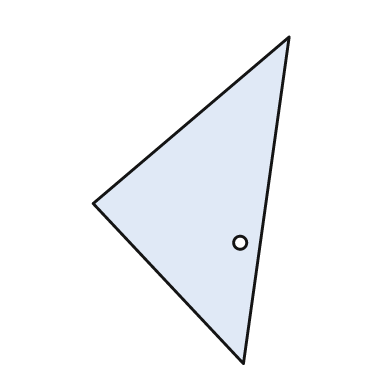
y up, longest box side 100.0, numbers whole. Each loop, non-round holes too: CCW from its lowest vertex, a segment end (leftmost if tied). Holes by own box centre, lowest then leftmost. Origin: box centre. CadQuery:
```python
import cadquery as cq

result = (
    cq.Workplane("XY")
    .moveTo(16.0, -50.0)
    .lineTo(30.0, 50.0)
    .lineTo(-30.0, -1.0)
    .close()
    .moveTo(15.0, -13.0)
    .circle(2.0)
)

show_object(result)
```